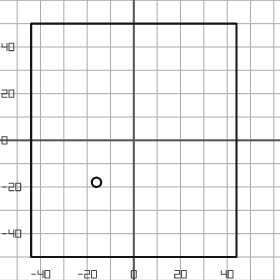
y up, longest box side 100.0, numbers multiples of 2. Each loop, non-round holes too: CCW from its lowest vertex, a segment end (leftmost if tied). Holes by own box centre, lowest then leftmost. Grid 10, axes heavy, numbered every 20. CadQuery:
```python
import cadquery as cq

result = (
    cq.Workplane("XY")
    .moveTo(-44.0, -50.0)
    .lineTo(44.0, -50.0)
    .lineTo(44.0, 50.0)
    .lineTo(-44.0, 50.0)
    .close()
    .moveTo(-16.0, -18.0)
    .circle(2.0)
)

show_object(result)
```